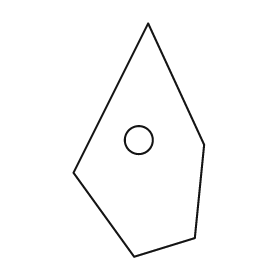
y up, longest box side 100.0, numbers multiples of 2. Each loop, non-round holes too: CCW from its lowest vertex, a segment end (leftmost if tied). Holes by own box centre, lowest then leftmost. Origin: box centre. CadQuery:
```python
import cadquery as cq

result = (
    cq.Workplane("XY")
    .moveTo(-2.0, -50.0)
    .lineTo(24.0, -42.0)
    .lineTo(28.0, -2.0)
    .lineTo(4.0, 50.0)
    .lineTo(-28.0, -14.0)
    .close()
    .moveTo(0.0, 0.0)
    .circle(6.0)
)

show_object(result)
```